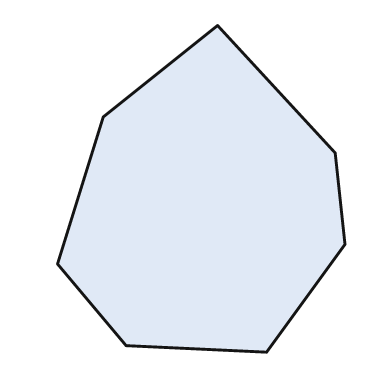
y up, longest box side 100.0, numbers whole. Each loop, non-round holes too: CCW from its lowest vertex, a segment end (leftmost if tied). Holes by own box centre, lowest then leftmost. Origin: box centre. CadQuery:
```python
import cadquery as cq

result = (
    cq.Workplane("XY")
    .moveTo(20.0, -50.0)
    .lineTo(44.0, -17.0)
    .lineTo(41.0, 11.0)
    .lineTo(5.0, 50.0)
    .lineTo(-30.0, 22.0)
    .lineTo(-44.0, -23.0)
    .lineTo(-23.0, -48.0)
    .close()
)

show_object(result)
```